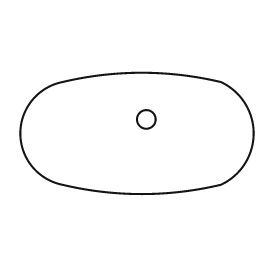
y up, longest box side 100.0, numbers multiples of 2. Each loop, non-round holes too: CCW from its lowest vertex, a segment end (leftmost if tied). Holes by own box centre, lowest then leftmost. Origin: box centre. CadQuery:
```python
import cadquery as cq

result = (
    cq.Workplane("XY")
    .moveTo(-32.0, -22.0)
    .threePointArc((2.0, -26.0), (36.0, -22.0))
    .threePointArc((50.0, 0.0), (36.0, 22.0))
    .threePointArc((2.0, 26.0), (-32.0, 22.0))
    .threePointArc((-50.0, 0.0), (-32.0, -22.0))
    .close()
    .moveTo(4.0, 6.0)
    .circle(4.0)
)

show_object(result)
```